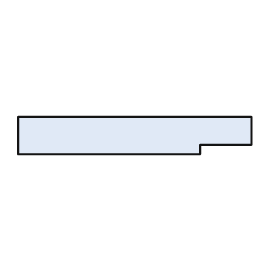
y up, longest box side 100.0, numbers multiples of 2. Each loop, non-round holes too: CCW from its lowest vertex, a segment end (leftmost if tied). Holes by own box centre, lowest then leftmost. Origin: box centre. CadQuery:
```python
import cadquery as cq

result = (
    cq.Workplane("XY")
    .moveTo(-50.0, -8.0)
    .lineTo(28.0, -8.0)
    .lineTo(28.0, -4.0)
    .lineTo(50.0, -4.0)
    .lineTo(50.0, 8.0)
    .lineTo(-50.0, 8.0)
    .close()
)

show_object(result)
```